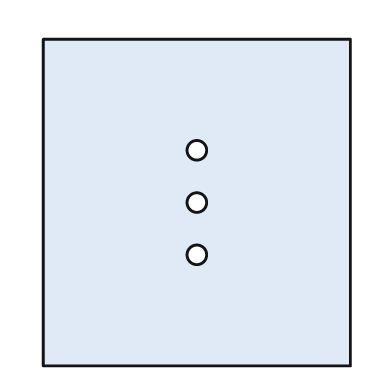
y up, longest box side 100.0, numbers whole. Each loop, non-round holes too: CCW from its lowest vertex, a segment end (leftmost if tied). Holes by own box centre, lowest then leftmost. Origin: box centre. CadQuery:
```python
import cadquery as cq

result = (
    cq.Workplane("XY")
    .moveTo(-47.0, -50.0)
    .lineTo(47.0, -50.0)
    .lineTo(47.0, 50.0)
    .lineTo(-47.0, 50.0)
    .close()
    .moveTo(0.0, -16.0)
    .circle(3.0)
    .moveTo(0.0, 0.0)
    .circle(3.0)
    .moveTo(0.0, 16.0)
    .circle(3.0)
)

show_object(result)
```